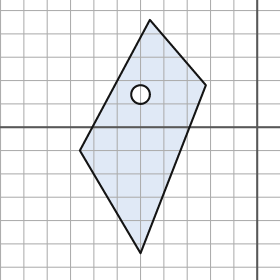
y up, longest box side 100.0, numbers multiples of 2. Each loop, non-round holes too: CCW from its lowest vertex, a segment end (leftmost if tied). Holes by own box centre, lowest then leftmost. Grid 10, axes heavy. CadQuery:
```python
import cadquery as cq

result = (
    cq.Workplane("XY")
    .moveTo(-50.0, -54.0)
    .lineTo(-22.0, 18.0)
    .lineTo(-46.0, 46.0)
    .lineTo(-76.0, -10.0)
    .close()
    .moveTo(-50.0, 14.0)
    .circle(4.0)
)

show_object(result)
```